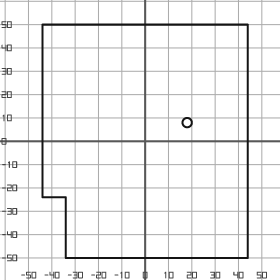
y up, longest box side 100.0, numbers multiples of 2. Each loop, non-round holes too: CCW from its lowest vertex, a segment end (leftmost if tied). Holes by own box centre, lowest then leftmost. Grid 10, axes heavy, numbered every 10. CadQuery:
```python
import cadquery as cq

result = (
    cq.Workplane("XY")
    .moveTo(-34.0, -50.0)
    .lineTo(44.0, -50.0)
    .lineTo(44.0, 50.0)
    .lineTo(-44.0, 50.0)
    .lineTo(-44.0, -24.0)
    .lineTo(-34.0, -24.0)
    .close()
    .moveTo(18.0, 8.0)
    .circle(2.0)
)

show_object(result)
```